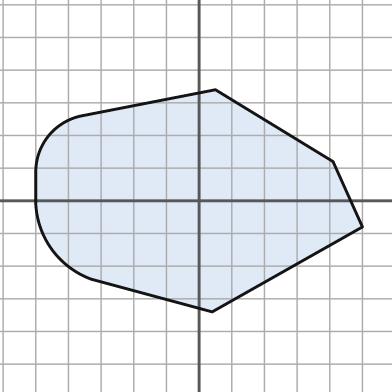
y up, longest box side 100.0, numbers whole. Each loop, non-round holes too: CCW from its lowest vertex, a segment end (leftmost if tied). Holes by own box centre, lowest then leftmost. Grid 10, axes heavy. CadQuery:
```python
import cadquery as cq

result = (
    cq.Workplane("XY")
    .moveTo(4.0, -34.0)
    .lineTo(50.0, -8.0)
    .lineTo(41.0, 12.0)
    .lineTo(5.0, 34.0)
    .lineTo(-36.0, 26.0)
    .threePointArc((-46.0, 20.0), (-50.0, 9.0))
    .lineTo(-50.0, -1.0)
    .threePointArc((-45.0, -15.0), (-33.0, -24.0))
    .close()
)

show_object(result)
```